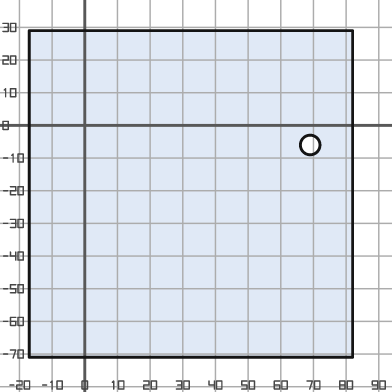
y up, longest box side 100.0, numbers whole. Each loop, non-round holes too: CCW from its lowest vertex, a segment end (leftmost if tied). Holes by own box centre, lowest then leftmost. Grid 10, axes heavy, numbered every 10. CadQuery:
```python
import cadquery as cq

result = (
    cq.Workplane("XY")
    .moveTo(-17.0, -71.0)
    .lineTo(82.0, -71.0)
    .lineTo(82.0, 29.0)
    .lineTo(-17.0, 29.0)
    .close()
    .moveTo(69.0, -6.0)
    .circle(3.0)
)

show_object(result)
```